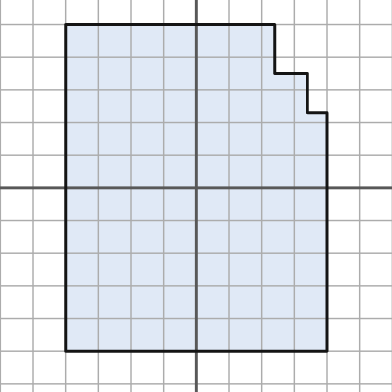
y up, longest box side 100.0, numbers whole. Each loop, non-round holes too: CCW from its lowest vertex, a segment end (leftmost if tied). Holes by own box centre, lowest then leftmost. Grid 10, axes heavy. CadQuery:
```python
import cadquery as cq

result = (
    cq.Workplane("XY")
    .moveTo(-40.0, -50.0)
    .lineTo(40.0, -50.0)
    .lineTo(40.0, 23.0)
    .lineTo(34.0, 23.0)
    .lineTo(34.0, 35.0)
    .lineTo(24.0, 35.0)
    .lineTo(24.0, 50.0)
    .lineTo(-40.0, 50.0)
    .close()
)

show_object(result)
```